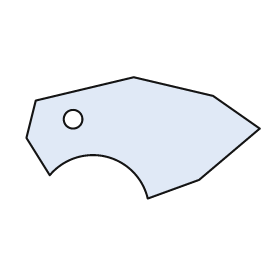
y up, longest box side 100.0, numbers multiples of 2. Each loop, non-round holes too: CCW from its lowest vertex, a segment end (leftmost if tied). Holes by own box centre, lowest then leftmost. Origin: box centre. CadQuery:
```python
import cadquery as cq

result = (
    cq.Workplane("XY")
    .moveTo(2.0, -26.0)
    .lineTo(24.0, -18.0)
    .lineTo(50.0, 4.0)
    .lineTo(30.0, 18.0)
    .lineTo(-4.0, 26.0)
    .lineTo(-46.0, 16.0)
    .lineTo(-50.0, 0.0)
    .lineTo(-40.0, -16.0)
    .threePointArc((-16.0, -8.0), (2.0, -26.0))
    .close()
    .moveTo(-30.0, 8.0)
    .circle(4.0)
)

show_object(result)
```